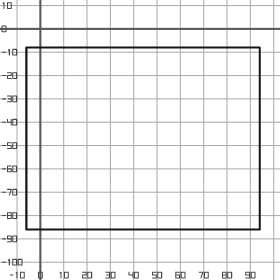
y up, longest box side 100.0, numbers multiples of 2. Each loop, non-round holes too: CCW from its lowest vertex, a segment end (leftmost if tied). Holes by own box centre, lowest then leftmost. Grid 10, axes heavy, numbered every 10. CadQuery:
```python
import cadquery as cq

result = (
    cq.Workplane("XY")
    .moveTo(-6.0, -86.0)
    .lineTo(94.0, -86.0)
    .lineTo(94.0, -8.0)
    .lineTo(-6.0, -8.0)
    .close()
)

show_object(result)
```